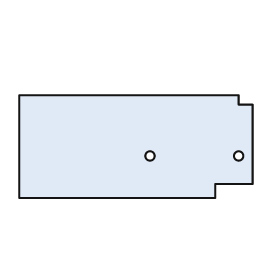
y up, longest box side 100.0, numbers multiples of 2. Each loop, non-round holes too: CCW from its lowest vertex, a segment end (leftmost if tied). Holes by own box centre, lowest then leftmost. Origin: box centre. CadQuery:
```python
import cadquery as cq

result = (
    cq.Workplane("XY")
    .moveTo(-50.0, -22.0)
    .lineTo(34.0, -22.0)
    .lineTo(34.0, -16.0)
    .lineTo(50.0, -16.0)
    .lineTo(50.0, 18.0)
    .lineTo(44.0, 18.0)
    .lineTo(44.0, 22.0)
    .lineTo(-50.0, 22.0)
    .close()
    .moveTo(6.0, -4.0)
    .circle(2.0)
    .moveTo(44.0, -4.0)
    .circle(2.0)
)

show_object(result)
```